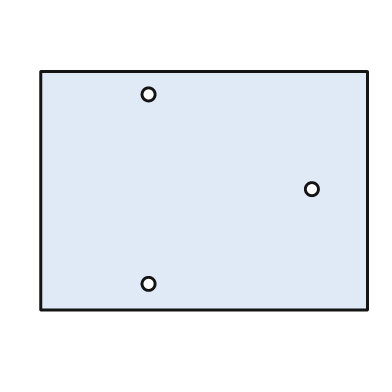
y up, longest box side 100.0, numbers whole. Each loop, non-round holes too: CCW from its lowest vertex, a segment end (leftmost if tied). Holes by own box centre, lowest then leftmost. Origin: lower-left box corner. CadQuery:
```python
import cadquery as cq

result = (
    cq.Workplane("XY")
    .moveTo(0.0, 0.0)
    .lineTo(100.0, 0.0)
    .lineTo(100.0, 73.0)
    .lineTo(0.0, 73.0)
    .close()
    .moveTo(33.0, 8.0)
    .circle(2.0)
    .moveTo(83.0, 37.0)
    .circle(2.0)
    .moveTo(33.0, 66.0)
    .circle(2.0)
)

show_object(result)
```